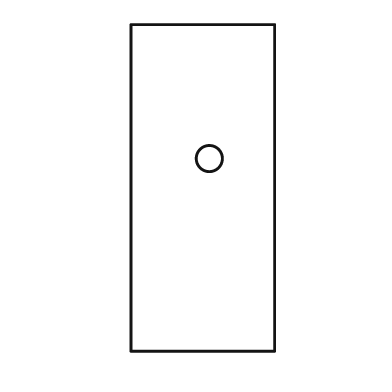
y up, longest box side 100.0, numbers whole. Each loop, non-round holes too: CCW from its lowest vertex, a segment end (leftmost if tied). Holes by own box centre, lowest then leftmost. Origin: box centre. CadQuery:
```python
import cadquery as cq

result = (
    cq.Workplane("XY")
    .moveTo(-22.0, -50.0)
    .lineTo(22.0, -50.0)
    .lineTo(22.0, 50.0)
    .lineTo(-22.0, 50.0)
    .close()
    .moveTo(2.0, 9.0)
    .circle(4.0)
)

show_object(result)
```